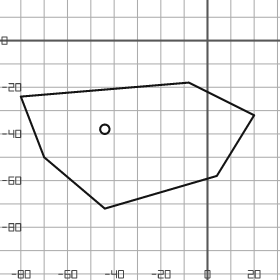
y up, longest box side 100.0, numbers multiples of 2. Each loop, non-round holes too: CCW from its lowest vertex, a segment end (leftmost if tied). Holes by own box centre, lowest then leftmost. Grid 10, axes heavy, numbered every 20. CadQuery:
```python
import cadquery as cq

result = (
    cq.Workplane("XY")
    .moveTo(-44.0, -72.0)
    .lineTo(4.0, -58.0)
    .lineTo(20.0, -32.0)
    .lineTo(-8.0, -18.0)
    .lineTo(-80.0, -24.0)
    .lineTo(-70.0, -50.0)
    .close()
    .moveTo(-44.0, -38.0)
    .circle(2.0)
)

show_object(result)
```